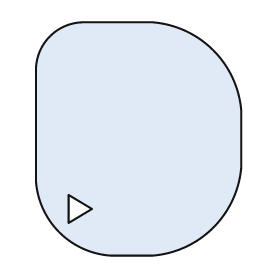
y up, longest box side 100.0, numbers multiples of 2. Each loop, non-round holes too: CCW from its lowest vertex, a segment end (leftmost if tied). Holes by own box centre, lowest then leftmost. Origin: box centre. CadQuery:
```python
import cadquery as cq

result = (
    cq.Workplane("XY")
    .moveTo(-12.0, -50.0)
    .lineTo(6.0, -50.0)
    .threePointArc((32.0, -38.0), (44.0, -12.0))
    .lineTo(44.0, 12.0)
    .threePointArc((32.0, 38.0), (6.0, 50.0))
    .lineTo(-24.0, 50.0)
    .threePointArc((-38.0, 44.0), (-44.0, 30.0))
    .lineTo(-44.0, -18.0)
    .threePointArc((-34.0, -40.0), (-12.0, -50.0))
    .close()
    .moveTo(-30.0, -36.0)
    .lineTo(-20.0, -30.0)
    .lineTo(-30.0, -24.0)
    .close()
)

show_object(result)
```